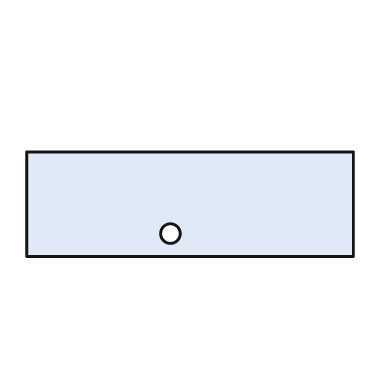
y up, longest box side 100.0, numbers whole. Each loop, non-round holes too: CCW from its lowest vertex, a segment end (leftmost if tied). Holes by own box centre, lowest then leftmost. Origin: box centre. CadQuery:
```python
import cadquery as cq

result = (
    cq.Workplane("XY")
    .moveTo(-50.0, -16.0)
    .lineTo(50.0, -16.0)
    .lineTo(50.0, 16.0)
    .lineTo(-50.0, 16.0)
    .close()
    .moveTo(-6.0, -9.0)
    .circle(3.0)
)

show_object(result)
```